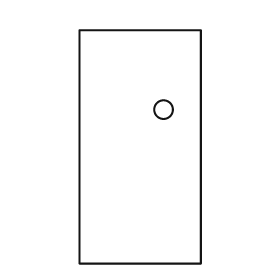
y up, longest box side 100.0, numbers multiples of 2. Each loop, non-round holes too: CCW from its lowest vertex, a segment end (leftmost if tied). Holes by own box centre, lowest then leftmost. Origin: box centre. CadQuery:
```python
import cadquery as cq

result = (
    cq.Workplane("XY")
    .moveTo(-26.0, -50.0)
    .lineTo(26.0, -50.0)
    .lineTo(26.0, 50.0)
    .lineTo(-26.0, 50.0)
    .close()
    .moveTo(10.0, 16.0)
    .circle(4.0)
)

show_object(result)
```